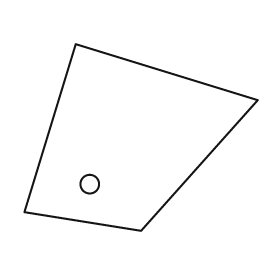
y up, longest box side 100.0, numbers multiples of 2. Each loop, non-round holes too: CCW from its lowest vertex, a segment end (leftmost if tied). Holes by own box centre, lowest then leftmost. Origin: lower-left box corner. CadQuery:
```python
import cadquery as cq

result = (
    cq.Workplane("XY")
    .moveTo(50.0, 0.0)
    .lineTo(100.0, 56.0)
    .lineTo(22.0, 80.0)
    .lineTo(0.0, 8.0)
    .close()
    .moveTo(28.0, 20.0)
    .circle(4.0)
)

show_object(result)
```